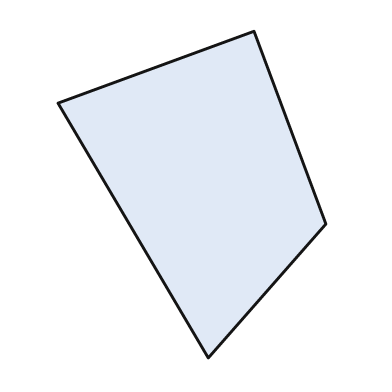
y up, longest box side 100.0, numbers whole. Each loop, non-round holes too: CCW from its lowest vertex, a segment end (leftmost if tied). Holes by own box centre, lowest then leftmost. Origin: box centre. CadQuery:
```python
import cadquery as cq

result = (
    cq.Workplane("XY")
    .moveTo(5.0, -50.0)
    .lineTo(41.0, -9.0)
    .lineTo(19.0, 50.0)
    .lineTo(-41.0, 28.0)
    .close()
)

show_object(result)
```